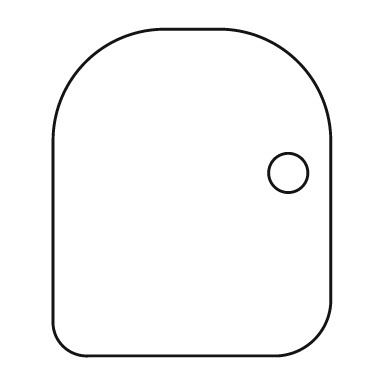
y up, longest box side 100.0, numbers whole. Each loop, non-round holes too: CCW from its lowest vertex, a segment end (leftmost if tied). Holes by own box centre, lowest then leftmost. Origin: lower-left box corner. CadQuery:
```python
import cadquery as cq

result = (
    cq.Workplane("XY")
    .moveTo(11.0, 0.0)
    .lineTo(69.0, 0.0)
    .threePointArc((80.0, 5.0), (85.0, 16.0))
    .lineTo(85.0, 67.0)
    .threePointArc((75.0, 90.0), (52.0, 100.0))
    .lineTo(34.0, 100.0)
    .threePointArc((10.0, 90.0), (0.0, 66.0))
    .lineTo(0.0, 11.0)
    .threePointArc((3.0, 3.0), (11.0, 0.0))
    .close()
    .moveTo(72.0, 56.0)
    .circle(6.0)
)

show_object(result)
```